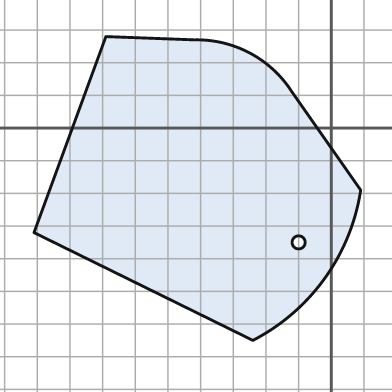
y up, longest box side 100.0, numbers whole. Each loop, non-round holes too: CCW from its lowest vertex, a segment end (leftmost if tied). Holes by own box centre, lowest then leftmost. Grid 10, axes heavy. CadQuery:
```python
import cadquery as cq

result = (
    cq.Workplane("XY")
    .moveTo(-24.0, -65.0)
    .threePointArc((-2.0, -46.0), (9.0, -19.0))
    .lineTo(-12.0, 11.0)
    .threePointArc((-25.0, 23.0), (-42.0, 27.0))
    .lineTo(-69.0, 28.0)
    .lineTo(-91.0, -32.0)
    .close()
    .moveTo(-10.0, -35.0)
    .circle(2.0)
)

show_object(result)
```